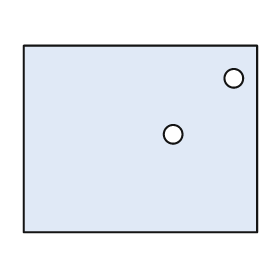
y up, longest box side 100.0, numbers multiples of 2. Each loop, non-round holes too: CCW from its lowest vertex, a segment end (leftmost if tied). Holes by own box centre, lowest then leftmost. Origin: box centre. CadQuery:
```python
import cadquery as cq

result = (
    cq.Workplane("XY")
    .moveTo(-50.0, -40.0)
    .lineTo(50.0, -40.0)
    .lineTo(50.0, 40.0)
    .lineTo(-50.0, 40.0)
    .close()
    .moveTo(14.0, 2.0)
    .circle(4.0)
    .moveTo(40.0, 26.0)
    .circle(4.0)
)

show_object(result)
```